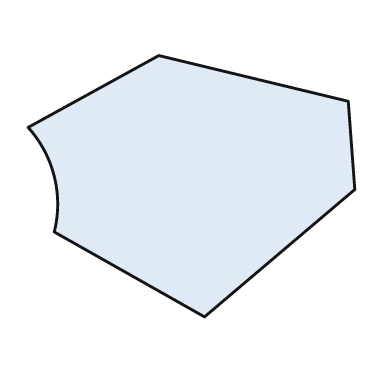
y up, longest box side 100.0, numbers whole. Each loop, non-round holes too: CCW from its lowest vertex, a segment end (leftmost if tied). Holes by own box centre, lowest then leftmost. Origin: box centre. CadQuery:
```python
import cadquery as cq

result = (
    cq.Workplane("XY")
    .moveTo(4.0, -40.0)
    .lineTo(50.0, -1.0)
    .lineTo(48.0, 26.0)
    .lineTo(-10.0, 40.0)
    .lineTo(-50.0, 18.0)
    .threePointArc((-42.0, 3.0), (-42.0, -14.0))
    .close()
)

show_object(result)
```